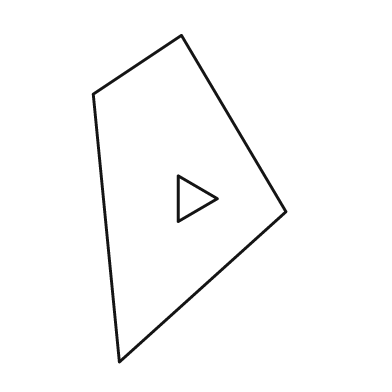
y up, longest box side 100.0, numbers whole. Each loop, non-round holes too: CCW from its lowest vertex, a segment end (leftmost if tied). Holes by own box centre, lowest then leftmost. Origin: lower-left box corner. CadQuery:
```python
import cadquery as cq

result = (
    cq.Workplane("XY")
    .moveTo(8.0, 0.0)
    .lineTo(59.0, 46.0)
    .lineTo(27.0, 100.0)
    .lineTo(0.0, 82.0)
    .close()
    .moveTo(26.0, 43.0)
    .lineTo(38.0, 50.0)
    .lineTo(26.0, 57.0)
    .close()
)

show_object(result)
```